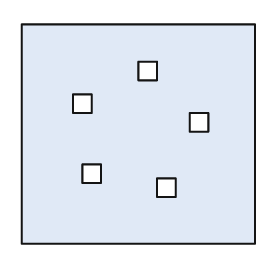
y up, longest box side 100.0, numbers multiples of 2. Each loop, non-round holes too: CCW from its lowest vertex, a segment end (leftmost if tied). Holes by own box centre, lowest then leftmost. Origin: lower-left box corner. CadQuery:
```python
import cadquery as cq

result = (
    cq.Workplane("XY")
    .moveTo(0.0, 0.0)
    .lineTo(100.0, 0.0)
    .lineTo(100.0, 94.0)
    .lineTo(0.0, 94.0)
    .close()
    .moveTo(58.0, 20.0)
    .lineTo(66.0, 20.0)
    .lineTo(66.0, 28.0)
    .lineTo(58.0, 28.0)
    .close()
    .moveTo(26.0, 26.0)
    .lineTo(34.0, 26.0)
    .lineTo(34.0, 34.0)
    .lineTo(26.0, 34.0)
    .close()
    .moveTo(72.0, 48.0)
    .lineTo(80.0, 48.0)
    .lineTo(80.0, 56.0)
    .lineTo(72.0, 56.0)
    .close()
    .moveTo(22.0, 56.0)
    .lineTo(30.0, 56.0)
    .lineTo(30.0, 64.0)
    .lineTo(22.0, 64.0)
    .close()
    .moveTo(50.0, 70.0)
    .lineTo(58.0, 70.0)
    .lineTo(58.0, 78.0)
    .lineTo(50.0, 78.0)
    .close()
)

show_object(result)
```